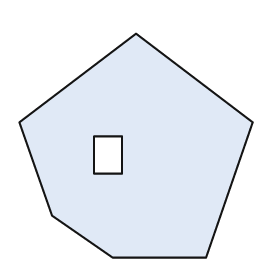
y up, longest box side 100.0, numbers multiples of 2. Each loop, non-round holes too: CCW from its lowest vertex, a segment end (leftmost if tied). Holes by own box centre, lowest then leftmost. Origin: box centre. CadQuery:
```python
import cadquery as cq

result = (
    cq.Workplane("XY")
    .moveTo(-10.0, -48.0)
    .lineTo(30.0, -48.0)
    .lineTo(50.0, 10.0)
    .lineTo(0.0, 48.0)
    .lineTo(-50.0, 10.0)
    .lineTo(-36.0, -30.0)
    .close()
    .moveTo(-18.0, -12.0)
    .lineTo(-6.0, -12.0)
    .lineTo(-6.0, 4.0)
    .lineTo(-18.0, 4.0)
    .close()
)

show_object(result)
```